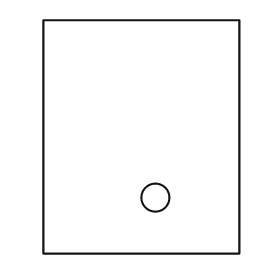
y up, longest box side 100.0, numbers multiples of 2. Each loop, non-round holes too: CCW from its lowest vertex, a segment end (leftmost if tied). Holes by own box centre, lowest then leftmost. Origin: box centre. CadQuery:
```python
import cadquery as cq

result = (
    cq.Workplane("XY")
    .moveTo(-42.0, -50.0)
    .lineTo(42.0, -50.0)
    .lineTo(42.0, 50.0)
    .lineTo(-42.0, 50.0)
    .close()
    .moveTo(6.0, -26.0)
    .circle(6.0)
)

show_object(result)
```